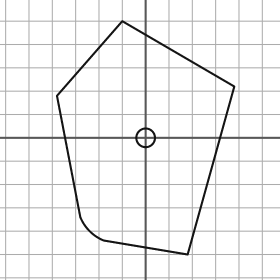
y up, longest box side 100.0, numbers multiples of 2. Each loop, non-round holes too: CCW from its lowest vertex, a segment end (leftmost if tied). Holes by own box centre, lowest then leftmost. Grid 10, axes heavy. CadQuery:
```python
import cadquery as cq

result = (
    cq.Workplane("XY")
    .moveTo(18.0, -50.0)
    .lineTo(38.0, 22.0)
    .lineTo(-10.0, 50.0)
    .lineTo(-38.0, 18.0)
    .lineTo(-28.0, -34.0)
    .threePointArc((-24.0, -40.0), (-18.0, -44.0))
    .close()
    .moveTo(0.0, 0.0)
    .circle(4.0)
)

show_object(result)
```